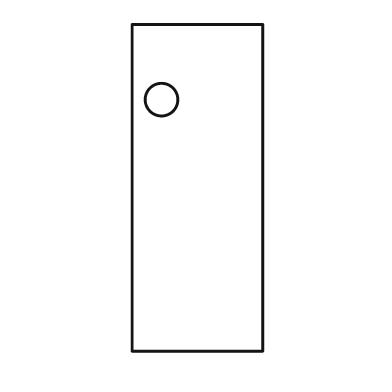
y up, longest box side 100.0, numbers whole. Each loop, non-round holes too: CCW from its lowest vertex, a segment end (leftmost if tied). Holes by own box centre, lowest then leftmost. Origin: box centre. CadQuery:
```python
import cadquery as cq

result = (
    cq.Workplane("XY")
    .moveTo(-20.0, -50.0)
    .lineTo(20.0, -50.0)
    .lineTo(20.0, 50.0)
    .lineTo(-20.0, 50.0)
    .close()
    .moveTo(-11.0, 27.0)
    .circle(5.0)
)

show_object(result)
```